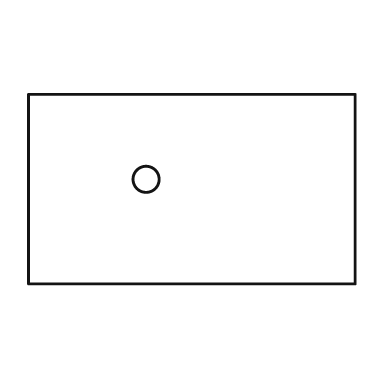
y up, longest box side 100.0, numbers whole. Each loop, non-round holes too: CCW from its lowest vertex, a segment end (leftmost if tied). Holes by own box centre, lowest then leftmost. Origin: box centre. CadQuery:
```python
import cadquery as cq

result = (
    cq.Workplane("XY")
    .moveTo(-50.0, -29.0)
    .lineTo(50.0, -29.0)
    .lineTo(50.0, 29.0)
    .lineTo(-50.0, 29.0)
    .close()
    .moveTo(-14.0, 3.0)
    .circle(4.0)
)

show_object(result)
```